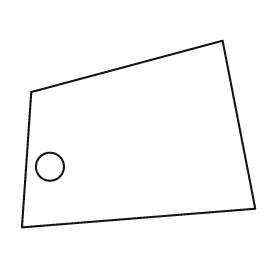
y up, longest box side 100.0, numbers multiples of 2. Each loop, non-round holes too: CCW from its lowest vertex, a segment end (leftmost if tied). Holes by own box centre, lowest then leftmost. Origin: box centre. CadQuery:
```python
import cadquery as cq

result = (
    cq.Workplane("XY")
    .moveTo(-50.0, -40.0)
    .lineTo(50.0, -32.0)
    .lineTo(36.0, 40.0)
    .lineTo(-46.0, 18.0)
    .close()
    .moveTo(-38.0, -14.0)
    .circle(6.0)
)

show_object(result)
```